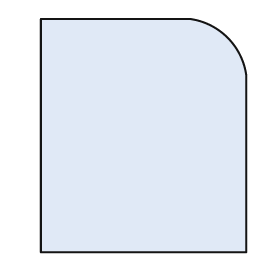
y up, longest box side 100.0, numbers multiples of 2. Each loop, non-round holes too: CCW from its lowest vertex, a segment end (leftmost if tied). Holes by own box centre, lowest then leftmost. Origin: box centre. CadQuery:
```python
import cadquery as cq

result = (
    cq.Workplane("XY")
    .moveTo(-44.0, -50.0)
    .lineTo(44.0, -50.0)
    .lineTo(44.0, 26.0)
    .threePointArc((36.0, 42.0), (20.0, 50.0))
    .lineTo(-44.0, 50.0)
    .close()
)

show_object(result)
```